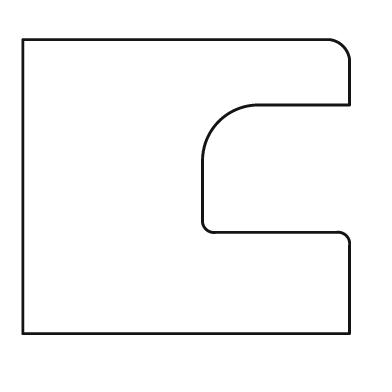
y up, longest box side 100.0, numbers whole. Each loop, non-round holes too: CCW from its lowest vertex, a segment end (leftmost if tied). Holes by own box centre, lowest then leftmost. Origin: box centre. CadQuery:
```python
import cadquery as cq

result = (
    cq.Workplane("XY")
    .moveTo(-50.0, -45.0)
    .lineTo(50.0, -45.0)
    .lineTo(50.0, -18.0)
    .threePointArc((49.0, -15.0), (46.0, -14.0))
    .lineTo(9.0, -14.0)
    .threePointArc((6.0, -13.0), (5.0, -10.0))
    .lineTo(5.0, 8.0)
    .threePointArc((10.0, 20.0), (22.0, 25.0))
    .lineTo(50.0, 25.0)
    .lineTo(50.0, 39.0)
    .threePointArc((48.0, 43.0), (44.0, 45.0))
    .lineTo(-50.0, 45.0)
    .close()
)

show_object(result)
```